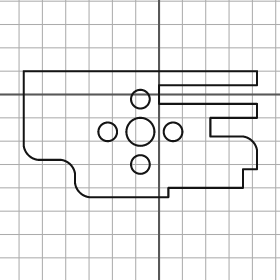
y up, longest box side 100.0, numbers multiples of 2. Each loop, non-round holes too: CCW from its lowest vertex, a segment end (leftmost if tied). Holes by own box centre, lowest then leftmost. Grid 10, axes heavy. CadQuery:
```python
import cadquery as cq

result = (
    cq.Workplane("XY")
    .moveTo(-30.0, -44.0)
    .lineTo(4.0, -44.0)
    .lineTo(4.0, -40.0)
    .lineTo(36.0, -40.0)
    .lineTo(36.0, -32.0)
    .lineTo(42.0, -32.0)
    .lineTo(42.0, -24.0)
    .threePointArc((40.0, -20.0), (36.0, -18.0))
    .lineTo(22.0, -18.0)
    .lineTo(22.0, -10.0)
    .lineTo(42.0, -10.0)
    .lineTo(42.0, -4.0)
    .lineTo(0.0, -4.0)
    .lineTo(0.0, 4.0)
    .lineTo(42.0, 4.0)
    .lineTo(42.0, 10.0)
    .lineTo(-58.0, 10.0)
    .lineTo(-58.0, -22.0)
    .threePointArc((-56.0, -26.0), (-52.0, -28.0))
    .lineTo(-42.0, -28.0)
    .threePointArc((-38.0, -30.0), (-36.0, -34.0))
    .lineTo(-36.0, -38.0)
    .threePointArc((-34.0, -42.0), (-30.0, -44.0))
    .close()
    .moveTo(-8.0, -30.0)
    .circle(4.0)
    .moveTo(-22.0, -16.0)
    .circle(4.0)
    .moveTo(-8.0, -16.0)
    .circle(6.0)
    .moveTo(6.0, -16.0)
    .circle(4.0)
    .moveTo(-8.0, -2.0)
    .circle(4.0)
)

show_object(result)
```